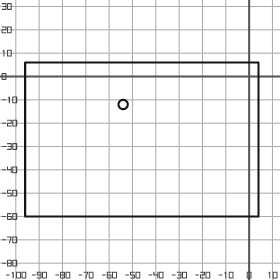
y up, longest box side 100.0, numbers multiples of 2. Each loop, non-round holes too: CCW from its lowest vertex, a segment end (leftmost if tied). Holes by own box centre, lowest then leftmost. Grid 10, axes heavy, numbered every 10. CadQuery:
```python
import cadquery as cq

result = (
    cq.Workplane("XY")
    .moveTo(-96.0, -60.0)
    .lineTo(4.0, -60.0)
    .lineTo(4.0, 6.0)
    .lineTo(-96.0, 6.0)
    .close()
    .moveTo(-54.0, -12.0)
    .circle(2.0)
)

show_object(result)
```